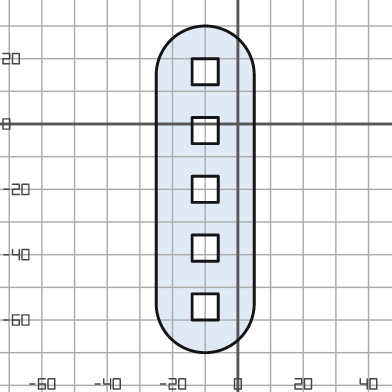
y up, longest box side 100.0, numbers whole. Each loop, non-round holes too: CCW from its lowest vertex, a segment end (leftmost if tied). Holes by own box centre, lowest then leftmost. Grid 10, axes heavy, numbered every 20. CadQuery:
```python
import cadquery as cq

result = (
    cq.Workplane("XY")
    .moveTo(-25.0, -55.0)
    .threePointArc((-10.0, -70.0), (5.0, -55.0))
    .lineTo(5.0, 15.0)
    .threePointArc((-10.0, 30.0), (-25.0, 15.0))
    .close()
    .moveTo(-14.0, -60.0)
    .lineTo(-6.0, -60.0)
    .lineTo(-6.0, -52.0)
    .lineTo(-14.0, -52.0)
    .close()
    .moveTo(-14.0, -42.0)
    .lineTo(-6.0, -42.0)
    .lineTo(-6.0, -34.0)
    .lineTo(-14.0, -34.0)
    .close()
    .moveTo(-14.0, -24.0)
    .lineTo(-6.0, -24.0)
    .lineTo(-6.0, -16.0)
    .lineTo(-14.0, -16.0)
    .close()
    .moveTo(-14.0, -6.0)
    .lineTo(-6.0, -6.0)
    .lineTo(-6.0, 2.0)
    .lineTo(-14.0, 2.0)
    .close()
    .moveTo(-14.0, 12.0)
    .lineTo(-6.0, 12.0)
    .lineTo(-6.0, 20.0)
    .lineTo(-14.0, 20.0)
    .close()
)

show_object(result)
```